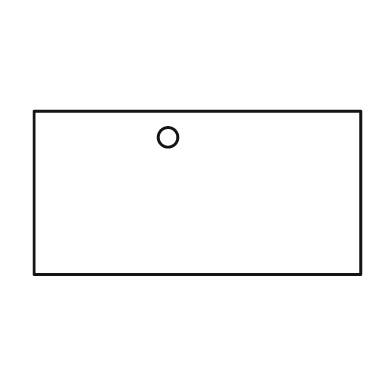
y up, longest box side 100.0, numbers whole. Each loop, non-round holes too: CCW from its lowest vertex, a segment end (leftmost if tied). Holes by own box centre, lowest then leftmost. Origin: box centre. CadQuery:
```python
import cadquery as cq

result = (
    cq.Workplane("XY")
    .moveTo(-50.0, -25.0)
    .lineTo(50.0, -25.0)
    .lineTo(50.0, 25.0)
    .lineTo(-50.0, 25.0)
    .close()
    .moveTo(-9.0, 17.0)
    .circle(3.0)
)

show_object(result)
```